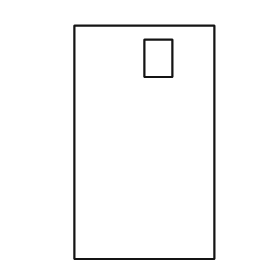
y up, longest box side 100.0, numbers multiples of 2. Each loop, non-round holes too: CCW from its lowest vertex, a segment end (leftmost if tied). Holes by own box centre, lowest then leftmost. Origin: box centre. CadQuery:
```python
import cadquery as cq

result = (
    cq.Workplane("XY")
    .moveTo(-30.0, -50.0)
    .lineTo(30.0, -50.0)
    .lineTo(30.0, 50.0)
    .lineTo(-30.0, 50.0)
    .close()
    .moveTo(0.0, 28.0)
    .lineTo(12.0, 28.0)
    .lineTo(12.0, 44.0)
    .lineTo(0.0, 44.0)
    .close()
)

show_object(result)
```